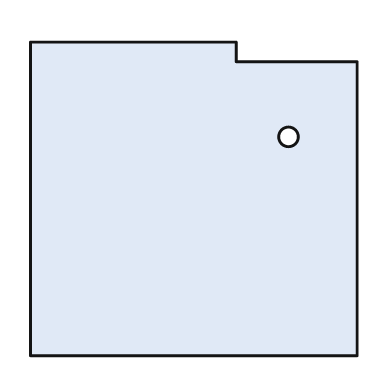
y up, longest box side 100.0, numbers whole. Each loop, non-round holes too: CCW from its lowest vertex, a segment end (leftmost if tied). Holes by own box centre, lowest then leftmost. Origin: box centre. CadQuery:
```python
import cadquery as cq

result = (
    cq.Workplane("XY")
    .moveTo(-50.0, -48.0)
    .lineTo(50.0, -48.0)
    .lineTo(50.0, 42.0)
    .lineTo(13.0, 42.0)
    .lineTo(13.0, 48.0)
    .lineTo(-50.0, 48.0)
    .close()
    .moveTo(29.0, 19.0)
    .circle(3.0)
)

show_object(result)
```